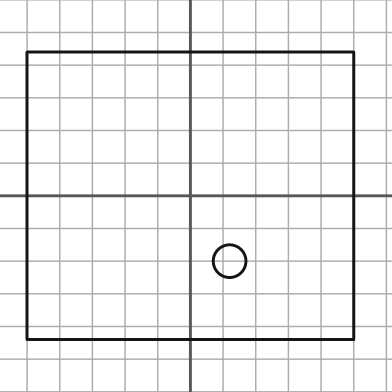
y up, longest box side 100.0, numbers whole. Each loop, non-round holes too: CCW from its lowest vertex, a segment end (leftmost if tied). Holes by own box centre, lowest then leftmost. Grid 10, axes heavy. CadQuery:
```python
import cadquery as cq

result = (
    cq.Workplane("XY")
    .moveTo(-50.0, -44.0)
    .lineTo(50.0, -44.0)
    .lineTo(50.0, 44.0)
    .lineTo(-50.0, 44.0)
    .close()
    .moveTo(12.0, -20.0)
    .circle(5.0)
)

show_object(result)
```